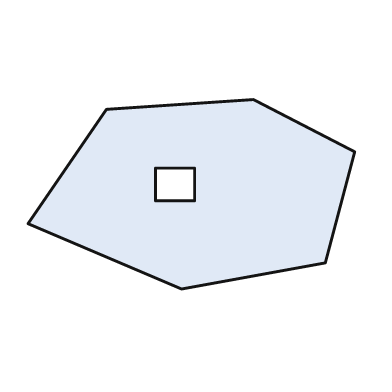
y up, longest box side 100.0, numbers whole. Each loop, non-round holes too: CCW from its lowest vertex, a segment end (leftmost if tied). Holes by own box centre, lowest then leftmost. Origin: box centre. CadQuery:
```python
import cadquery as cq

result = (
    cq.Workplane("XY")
    .moveTo(-3.0, -29.0)
    .lineTo(41.0, -21.0)
    .lineTo(50.0, 13.0)
    .lineTo(19.0, 29.0)
    .lineTo(-26.0, 26.0)
    .lineTo(-50.0, -9.0)
    .close()
    .moveTo(-11.0, -2.0)
    .lineTo(1.0, -2.0)
    .lineTo(1.0, 8.0)
    .lineTo(-11.0, 8.0)
    .close()
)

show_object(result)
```